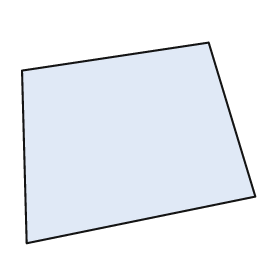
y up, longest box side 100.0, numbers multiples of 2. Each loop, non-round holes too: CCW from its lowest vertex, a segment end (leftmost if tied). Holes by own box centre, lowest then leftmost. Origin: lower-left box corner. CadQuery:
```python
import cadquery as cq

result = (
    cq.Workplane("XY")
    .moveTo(2.0, 0.0)
    .lineTo(100.0, 20.0)
    .lineTo(80.0, 86.0)
    .lineTo(0.0, 74.0)
    .close()
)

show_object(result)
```